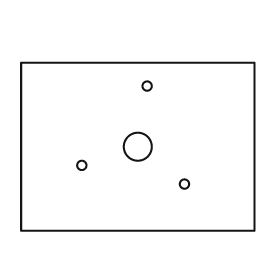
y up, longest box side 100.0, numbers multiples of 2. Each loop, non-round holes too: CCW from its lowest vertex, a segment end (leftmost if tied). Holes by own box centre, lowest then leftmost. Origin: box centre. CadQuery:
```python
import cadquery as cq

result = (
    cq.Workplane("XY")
    .moveTo(-50.0, -36.0)
    .lineTo(50.0, -36.0)
    .lineTo(50.0, 36.0)
    .lineTo(-50.0, 36.0)
    .close()
    .moveTo(20.0, -16.0)
    .circle(2.0)
    .moveTo(-24.0, -8.0)
    .circle(2.0)
    .moveTo(0.0, 0.0)
    .circle(6.0)
    .moveTo(4.0, 26.0)
    .circle(2.0)
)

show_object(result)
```